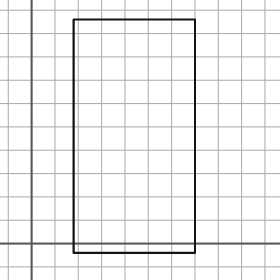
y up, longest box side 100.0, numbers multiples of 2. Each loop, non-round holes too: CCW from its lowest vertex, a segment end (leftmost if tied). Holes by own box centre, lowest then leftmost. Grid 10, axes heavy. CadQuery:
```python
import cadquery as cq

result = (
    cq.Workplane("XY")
    .moveTo(18.0, -4.0)
    .lineTo(70.0, -4.0)
    .lineTo(70.0, 96.0)
    .lineTo(18.0, 96.0)
    .close()
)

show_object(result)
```